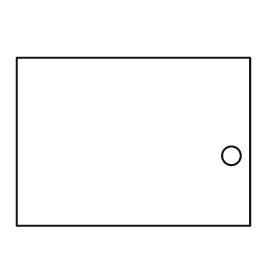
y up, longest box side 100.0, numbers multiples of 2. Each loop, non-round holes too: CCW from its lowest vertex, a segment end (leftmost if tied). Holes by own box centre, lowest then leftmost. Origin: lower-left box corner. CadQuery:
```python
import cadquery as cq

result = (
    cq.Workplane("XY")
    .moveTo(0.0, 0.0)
    .lineTo(100.0, 0.0)
    .lineTo(100.0, 72.0)
    .lineTo(0.0, 72.0)
    .close()
    .moveTo(92.0, 30.0)
    .circle(4.0)
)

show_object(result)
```